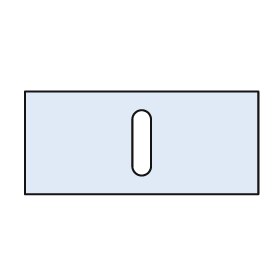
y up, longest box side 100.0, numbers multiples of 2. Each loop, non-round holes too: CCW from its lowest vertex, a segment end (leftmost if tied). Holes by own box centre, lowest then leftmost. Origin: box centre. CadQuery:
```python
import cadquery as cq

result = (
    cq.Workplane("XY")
    .moveTo(-50.0, -22.0)
    .lineTo(50.0, -22.0)
    .lineTo(50.0, 22.0)
    .lineTo(-50.0, 22.0)
    .close()
    .moveTo(-4.0, -10.0)
    .threePointArc((0.0, -14.0), (4.0, -10.0))
    .lineTo(4.0, 10.0)
    .threePointArc((0.0, 14.0), (-4.0, 10.0))
    .close()
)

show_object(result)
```